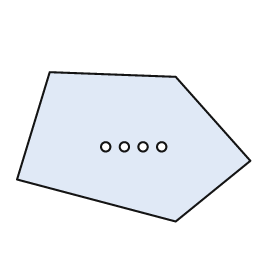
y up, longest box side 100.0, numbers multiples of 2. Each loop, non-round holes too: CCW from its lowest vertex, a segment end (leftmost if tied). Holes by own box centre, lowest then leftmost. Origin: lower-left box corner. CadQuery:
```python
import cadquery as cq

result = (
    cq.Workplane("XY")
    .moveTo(68.0, 0.0)
    .lineTo(100.0, 26.0)
    .lineTo(68.0, 62.0)
    .lineTo(14.0, 64.0)
    .lineTo(0.0, 18.0)
    .close()
    .moveTo(38.0, 32.0)
    .circle(2.0)
    .moveTo(46.0, 32.0)
    .circle(2.0)
    .moveTo(54.0, 32.0)
    .circle(2.0)
    .moveTo(62.0, 32.0)
    .circle(2.0)
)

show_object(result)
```